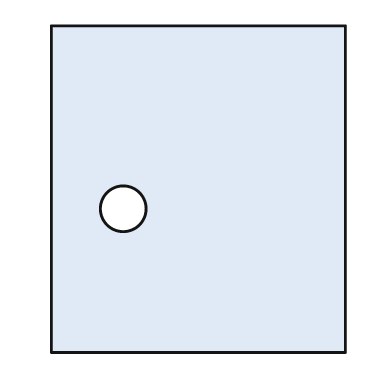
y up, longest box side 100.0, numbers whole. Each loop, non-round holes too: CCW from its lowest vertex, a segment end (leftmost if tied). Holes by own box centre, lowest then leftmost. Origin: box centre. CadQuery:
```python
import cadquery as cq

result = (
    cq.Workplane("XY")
    .moveTo(-45.0, -50.0)
    .lineTo(45.0, -50.0)
    .lineTo(45.0, 50.0)
    .lineTo(-45.0, 50.0)
    .close()
    .moveTo(-23.0, -6.0)
    .circle(7.0)
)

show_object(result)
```